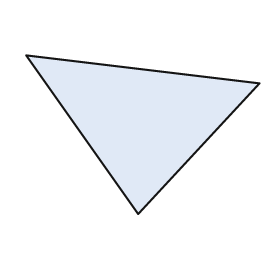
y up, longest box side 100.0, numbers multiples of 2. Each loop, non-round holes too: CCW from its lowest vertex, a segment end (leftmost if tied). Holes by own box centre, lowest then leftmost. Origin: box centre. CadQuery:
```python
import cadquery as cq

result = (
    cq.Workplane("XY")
    .moveTo(-2.0, -34.0)
    .lineTo(50.0, 22.0)
    .lineTo(-50.0, 34.0)
    .close()
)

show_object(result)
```